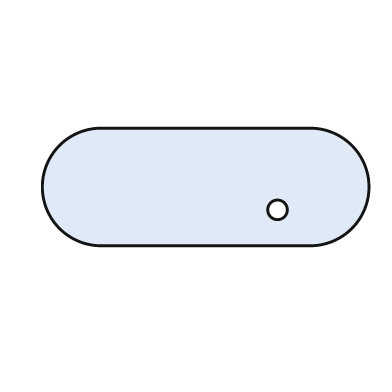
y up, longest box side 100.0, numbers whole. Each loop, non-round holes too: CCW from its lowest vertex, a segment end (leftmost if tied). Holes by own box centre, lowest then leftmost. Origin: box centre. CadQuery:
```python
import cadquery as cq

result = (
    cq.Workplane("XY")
    .moveTo(-32.0, -18.0)
    .lineTo(32.0, -18.0)
    .threePointArc((50.0, 0.0), (32.0, 18.0))
    .lineTo(-32.0, 18.0)
    .threePointArc((-50.0, 0.0), (-32.0, -18.0))
    .close()
    .moveTo(22.0, -7.0)
    .circle(3.0)
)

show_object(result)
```